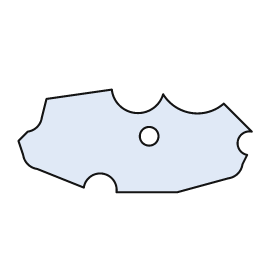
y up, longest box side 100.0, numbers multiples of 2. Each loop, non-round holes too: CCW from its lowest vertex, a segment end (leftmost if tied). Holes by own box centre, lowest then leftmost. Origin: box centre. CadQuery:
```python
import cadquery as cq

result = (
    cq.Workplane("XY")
    .moveTo(-8.0, -22.0)
    .lineTo(18.0, -22.0)
    .lineTo(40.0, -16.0)
    .threePointArc((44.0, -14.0), (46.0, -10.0))
    .lineTo(48.0, -6.0)
    .threePointArc((44.0, 0.0), (50.0, 4.0))
    .lineTo(38.0, 16.0)
    .threePointArc((24.0, 12.0), (12.0, 20.0))
    .threePointArc((0.0, 12.0), (-10.0, 22.0))
    .lineTo(-38.0, 18.0)
    .lineTo(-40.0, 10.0)
    .threePointArc((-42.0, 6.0), (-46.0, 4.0))
    .lineTo(-50.0, 0.0)
    .lineTo(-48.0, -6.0)
    .threePointArc((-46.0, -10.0), (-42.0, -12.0))
    .lineTo(-22.0, -20.0)
    .threePointArc((-14.0, -14.0), (-8.0, -22.0))
    .close()
    .moveTo(6.0, 2.0)
    .circle(4.0)
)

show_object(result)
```